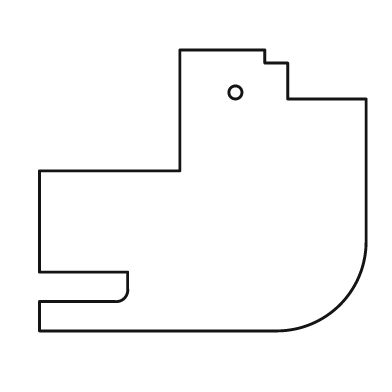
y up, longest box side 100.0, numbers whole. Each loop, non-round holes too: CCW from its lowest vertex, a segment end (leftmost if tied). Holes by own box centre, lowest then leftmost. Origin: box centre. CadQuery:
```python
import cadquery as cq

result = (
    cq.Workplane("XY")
    .moveTo(-50.0, -43.0)
    .lineTo(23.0, -43.0)
    .threePointArc((42.0, -35.0), (50.0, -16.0))
    .lineTo(50.0, 28.0)
    .lineTo(26.0, 28.0)
    .lineTo(26.0, 39.0)
    .lineTo(19.0, 39.0)
    .lineTo(19.0, 43.0)
    .lineTo(-7.0, 43.0)
    .lineTo(-7.0, 6.0)
    .lineTo(-50.0, 6.0)
    .lineTo(-50.0, -25.0)
    .lineTo(-23.0, -25.0)
    .lineTo(-23.0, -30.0)
    .threePointArc((-24.0, -33.0), (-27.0, -34.0))
    .lineTo(-50.0, -34.0)
    .close()
    .moveTo(10.0, 30.0)
    .circle(2.0)
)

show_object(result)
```